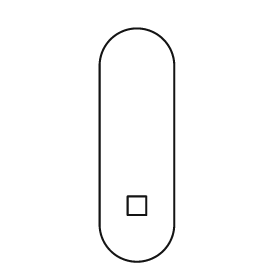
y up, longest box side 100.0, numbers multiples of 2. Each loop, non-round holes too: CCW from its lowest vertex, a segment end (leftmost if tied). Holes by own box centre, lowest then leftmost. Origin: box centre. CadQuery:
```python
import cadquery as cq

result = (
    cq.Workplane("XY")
    .moveTo(-16.0, -34.0)
    .threePointArc((0.0, -50.0), (16.0, -34.0))
    .lineTo(16.0, 34.0)
    .threePointArc((0.0, 50.0), (-16.0, 34.0))
    .close()
    .moveTo(-4.0, -30.0)
    .lineTo(4.0, -30.0)
    .lineTo(4.0, -22.0)
    .lineTo(-4.0, -22.0)
    .close()
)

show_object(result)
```